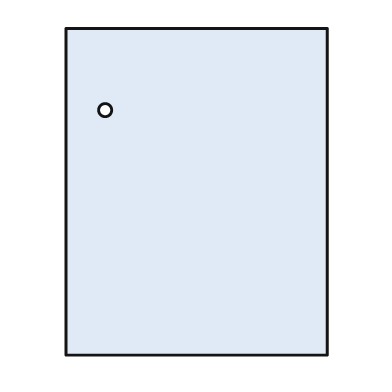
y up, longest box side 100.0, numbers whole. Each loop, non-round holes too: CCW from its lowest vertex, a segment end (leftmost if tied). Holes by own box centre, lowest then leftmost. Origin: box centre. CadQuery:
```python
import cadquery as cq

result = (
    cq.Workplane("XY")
    .moveTo(-40.0, -50.0)
    .lineTo(40.0, -50.0)
    .lineTo(40.0, 50.0)
    .lineTo(-40.0, 50.0)
    .close()
    .moveTo(-28.0, 25.0)
    .circle(2.0)
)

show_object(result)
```